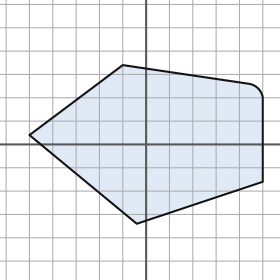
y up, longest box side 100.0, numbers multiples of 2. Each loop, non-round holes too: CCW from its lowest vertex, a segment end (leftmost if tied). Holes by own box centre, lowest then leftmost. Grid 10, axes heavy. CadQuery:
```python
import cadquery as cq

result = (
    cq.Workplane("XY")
    .moveTo(-4.0, -34.0)
    .lineTo(50.0, -16.0)
    .lineTo(50.0, 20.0)
    .threePointArc((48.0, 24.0), (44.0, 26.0))
    .lineTo(-10.0, 34.0)
    .lineTo(-50.0, 4.0)
    .close()
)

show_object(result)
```